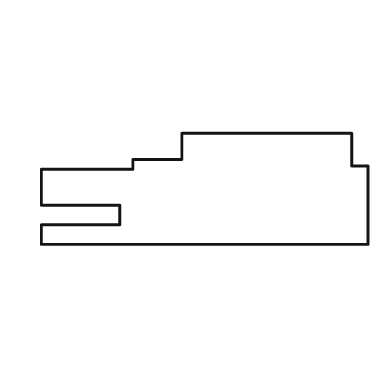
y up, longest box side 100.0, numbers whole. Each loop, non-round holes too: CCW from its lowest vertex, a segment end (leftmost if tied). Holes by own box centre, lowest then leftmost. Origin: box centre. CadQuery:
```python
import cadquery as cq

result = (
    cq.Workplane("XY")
    .moveTo(-50.0, -17.0)
    .lineTo(50.0, -17.0)
    .lineTo(50.0, 7.0)
    .lineTo(45.0, 7.0)
    .lineTo(45.0, 17.0)
    .lineTo(-7.0, 17.0)
    .lineTo(-7.0, 9.0)
    .lineTo(-22.0, 9.0)
    .lineTo(-22.0, 6.0)
    .lineTo(-50.0, 6.0)
    .lineTo(-50.0, -5.0)
    .lineTo(-26.0, -5.0)
    .lineTo(-26.0, -11.0)
    .lineTo(-50.0, -11.0)
    .close()
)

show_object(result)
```